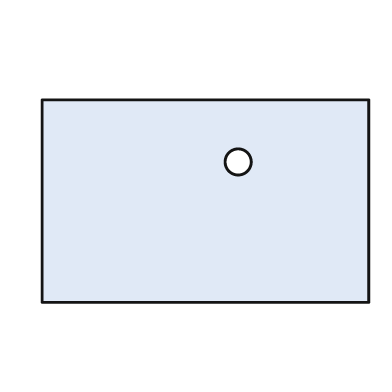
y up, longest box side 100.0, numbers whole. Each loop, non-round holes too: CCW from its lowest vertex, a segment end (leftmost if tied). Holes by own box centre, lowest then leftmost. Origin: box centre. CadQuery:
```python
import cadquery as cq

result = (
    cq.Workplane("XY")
    .moveTo(-50.0, -31.0)
    .lineTo(50.0, -31.0)
    .lineTo(50.0, 31.0)
    .lineTo(-50.0, 31.0)
    .close()
    .moveTo(10.0, 12.0)
    .circle(4.0)
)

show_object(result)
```